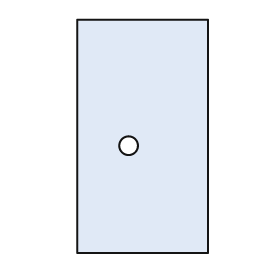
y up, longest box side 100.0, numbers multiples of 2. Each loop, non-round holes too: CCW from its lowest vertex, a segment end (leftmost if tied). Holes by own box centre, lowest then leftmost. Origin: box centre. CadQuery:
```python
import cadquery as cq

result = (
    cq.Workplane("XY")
    .moveTo(-28.0, -50.0)
    .lineTo(28.0, -50.0)
    .lineTo(28.0, 50.0)
    .lineTo(-28.0, 50.0)
    .close()
    .moveTo(-6.0, -4.0)
    .circle(4.0)
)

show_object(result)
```